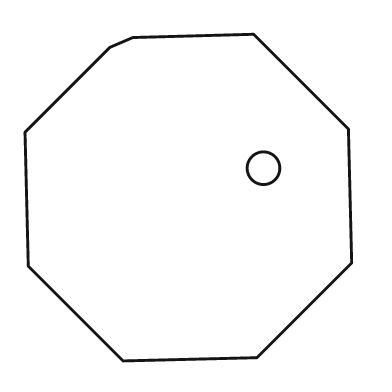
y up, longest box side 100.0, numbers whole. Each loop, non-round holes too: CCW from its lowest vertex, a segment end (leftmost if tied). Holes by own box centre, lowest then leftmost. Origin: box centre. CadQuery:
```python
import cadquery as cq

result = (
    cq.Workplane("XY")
    .moveTo(-20.0, -50.0)
    .lineTo(21.0, -49.0)
    .lineTo(50.0, -20.0)
    .lineTo(49.0, 21.0)
    .lineTo(20.0, 50.0)
    .lineTo(-17.0, 49.0)
    .lineTo(-24.0, 46.0)
    .lineTo(-50.0, 20.0)
    .lineTo(-49.0, -21.0)
    .close()
    .moveTo(23.0, 9.0)
    .circle(5.0)
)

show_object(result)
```